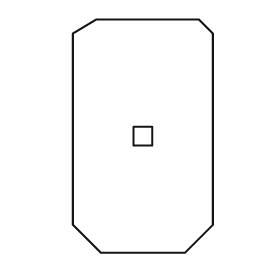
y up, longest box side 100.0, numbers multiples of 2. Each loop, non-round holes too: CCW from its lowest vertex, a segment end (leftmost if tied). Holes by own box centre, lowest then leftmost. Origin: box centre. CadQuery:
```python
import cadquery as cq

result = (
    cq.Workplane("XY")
    .moveTo(-18.0, -50.0)
    .lineTo(18.0, -50.0)
    .lineTo(30.0, -38.0)
    .lineTo(30.0, 44.0)
    .lineTo(24.0, 50.0)
    .lineTo(-20.0, 50.0)
    .lineTo(-30.0, 44.0)
    .lineTo(-30.0, -38.0)
    .close()
    .moveTo(-4.0, -4.0)
    .lineTo(4.0, -4.0)
    .lineTo(4.0, 4.0)
    .lineTo(-4.0, 4.0)
    .close()
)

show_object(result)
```